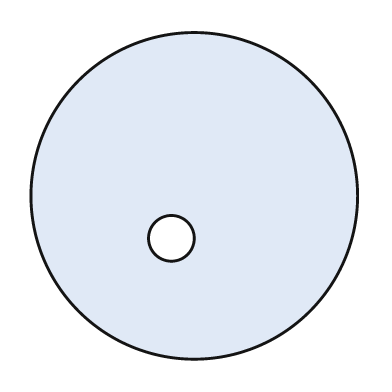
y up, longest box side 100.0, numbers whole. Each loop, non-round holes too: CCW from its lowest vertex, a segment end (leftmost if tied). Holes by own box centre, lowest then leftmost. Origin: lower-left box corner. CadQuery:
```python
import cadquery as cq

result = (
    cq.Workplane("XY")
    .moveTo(50.0, 50.0)
    .circle(50.0)
    .moveTo(43.0, 37.0)
    .circle(7.0)
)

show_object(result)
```